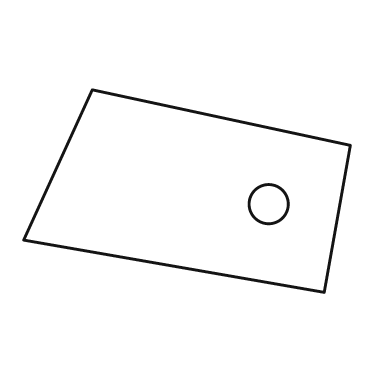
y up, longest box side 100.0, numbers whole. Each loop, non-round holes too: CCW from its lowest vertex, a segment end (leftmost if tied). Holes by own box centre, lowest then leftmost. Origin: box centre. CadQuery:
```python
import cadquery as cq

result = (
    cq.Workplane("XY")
    .moveTo(42.0, -31.0)
    .lineTo(50.0, 14.0)
    .lineTo(-29.0, 31.0)
    .lineTo(-50.0, -15.0)
    .close()
    .moveTo(25.0, -4.0)
    .circle(6.0)
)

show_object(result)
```